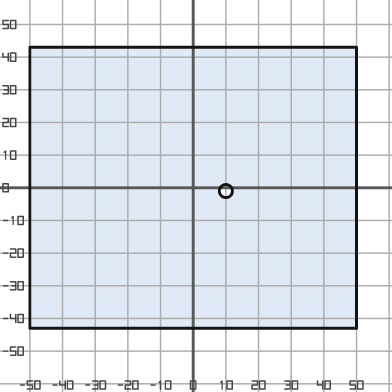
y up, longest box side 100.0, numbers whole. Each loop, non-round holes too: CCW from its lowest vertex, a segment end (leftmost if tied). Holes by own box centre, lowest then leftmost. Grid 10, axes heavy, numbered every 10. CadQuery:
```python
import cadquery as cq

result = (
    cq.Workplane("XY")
    .moveTo(-50.0, -43.0)
    .lineTo(50.0, -43.0)
    .lineTo(50.0, 43.0)
    .lineTo(-50.0, 43.0)
    .close()
    .moveTo(10.0, -1.0)
    .circle(2.0)
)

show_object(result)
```